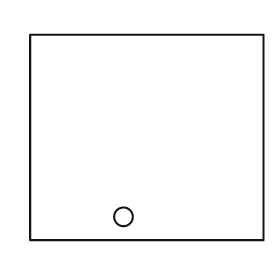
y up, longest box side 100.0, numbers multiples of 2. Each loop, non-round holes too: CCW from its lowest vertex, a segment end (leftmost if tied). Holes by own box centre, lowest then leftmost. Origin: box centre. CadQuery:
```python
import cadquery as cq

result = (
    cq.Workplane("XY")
    .moveTo(-50.0, -44.0)
    .lineTo(50.0, -44.0)
    .lineTo(50.0, 44.0)
    .lineTo(-50.0, 44.0)
    .close()
    .moveTo(-10.0, -34.0)
    .circle(4.0)
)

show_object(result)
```